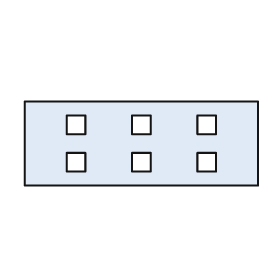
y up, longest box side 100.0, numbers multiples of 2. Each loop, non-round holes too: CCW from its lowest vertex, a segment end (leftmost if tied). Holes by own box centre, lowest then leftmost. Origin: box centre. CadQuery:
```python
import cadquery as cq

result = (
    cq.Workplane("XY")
    .moveTo(-50.0, -18.0)
    .lineTo(50.0, -18.0)
    .lineTo(50.0, 18.0)
    .lineTo(-50.0, 18.0)
    .close()
    .moveTo(-32.0, -12.0)
    .lineTo(-24.0, -12.0)
    .lineTo(-24.0, -4.0)
    .lineTo(-32.0, -4.0)
    .close()
    .moveTo(-4.0, -12.0)
    .lineTo(4.0, -12.0)
    .lineTo(4.0, -4.0)
    .lineTo(-4.0, -4.0)
    .close()
    .moveTo(24.0, -12.0)
    .lineTo(32.0, -12.0)
    .lineTo(32.0, -4.0)
    .lineTo(24.0, -4.0)
    .close()
    .moveTo(-32.0, 4.0)
    .lineTo(-24.0, 4.0)
    .lineTo(-24.0, 12.0)
    .lineTo(-32.0, 12.0)
    .close()
    .moveTo(-4.0, 4.0)
    .lineTo(4.0, 4.0)
    .lineTo(4.0, 12.0)
    .lineTo(-4.0, 12.0)
    .close()
    .moveTo(24.0, 4.0)
    .lineTo(32.0, 4.0)
    .lineTo(32.0, 12.0)
    .lineTo(24.0, 12.0)
    .close()
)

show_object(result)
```